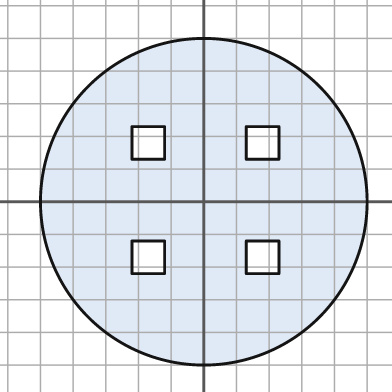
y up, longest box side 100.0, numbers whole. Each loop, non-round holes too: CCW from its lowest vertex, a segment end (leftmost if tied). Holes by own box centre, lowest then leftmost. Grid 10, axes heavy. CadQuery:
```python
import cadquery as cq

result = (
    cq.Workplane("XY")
    .moveTo(0.0, 0.0)
    .circle(50.0)
    .moveTo(-22.0, -22.0)
    .lineTo(-12.0, -22.0)
    .lineTo(-12.0, -12.0)
    .lineTo(-22.0, -12.0)
    .close()
    .moveTo(13.0, -22.0)
    .lineTo(23.0, -22.0)
    .lineTo(23.0, -12.0)
    .lineTo(13.0, -12.0)
    .close()
    .moveTo(-22.0, 13.0)
    .lineTo(-12.0, 13.0)
    .lineTo(-12.0, 23.0)
    .lineTo(-22.0, 23.0)
    .close()
    .moveTo(13.0, 13.0)
    .lineTo(23.0, 13.0)
    .lineTo(23.0, 23.0)
    .lineTo(13.0, 23.0)
    .close()
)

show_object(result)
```